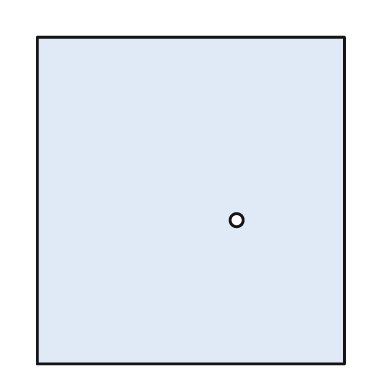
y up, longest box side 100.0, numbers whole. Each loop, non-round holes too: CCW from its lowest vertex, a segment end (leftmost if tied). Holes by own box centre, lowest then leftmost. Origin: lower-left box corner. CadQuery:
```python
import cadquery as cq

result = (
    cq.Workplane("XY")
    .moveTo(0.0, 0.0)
    .lineTo(94.0, 0.0)
    .lineTo(94.0, 100.0)
    .lineTo(0.0, 100.0)
    .close()
    .moveTo(61.0, 44.0)
    .circle(2.0)
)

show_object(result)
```